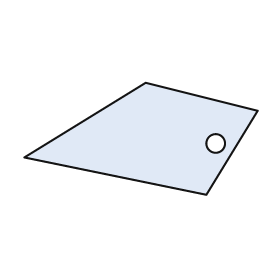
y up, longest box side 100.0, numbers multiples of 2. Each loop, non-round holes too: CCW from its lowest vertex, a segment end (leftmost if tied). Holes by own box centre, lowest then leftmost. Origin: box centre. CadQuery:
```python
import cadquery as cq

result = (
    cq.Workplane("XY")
    .moveTo(28.0, -24.0)
    .lineTo(50.0, 12.0)
    .lineTo(2.0, 24.0)
    .lineTo(-50.0, -8.0)
    .close()
    .moveTo(32.0, -2.0)
    .circle(4.0)
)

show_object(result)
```